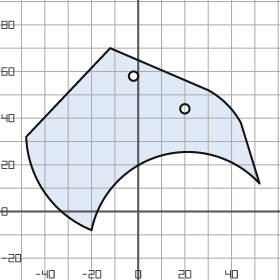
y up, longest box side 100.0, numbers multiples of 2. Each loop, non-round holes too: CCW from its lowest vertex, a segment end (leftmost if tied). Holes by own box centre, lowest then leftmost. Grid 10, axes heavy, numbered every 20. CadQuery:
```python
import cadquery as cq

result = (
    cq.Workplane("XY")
    .moveTo(-20.0, -8.0)
    .threePointArc((10.0, 24.0), (52.0, 12.0))
    .lineTo(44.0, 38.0)
    .threePointArc((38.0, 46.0), (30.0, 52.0))
    .lineTo(-12.0, 70.0)
    .lineTo(-48.0, 32.0)
    .threePointArc((-40.0, 8.0), (-20.0, -8.0))
    .close()
    .moveTo(20.0, 44.0)
    .circle(2.0)
    .moveTo(-2.0, 58.0)
    .circle(2.0)
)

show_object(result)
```